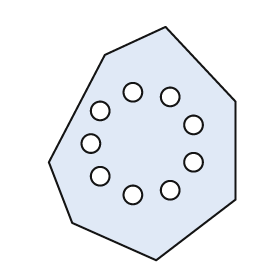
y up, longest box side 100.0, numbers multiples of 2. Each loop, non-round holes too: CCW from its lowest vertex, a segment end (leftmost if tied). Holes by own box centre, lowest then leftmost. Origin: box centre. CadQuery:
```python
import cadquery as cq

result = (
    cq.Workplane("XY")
    .moveTo(6.0, -50.0)
    .lineTo(40.0, -24.0)
    .lineTo(40.0, 18.0)
    .lineTo(10.0, 50.0)
    .lineTo(-16.0, 38.0)
    .lineTo(-40.0, -8.0)
    .lineTo(-30.0, -34.0)
    .close()
    .moveTo(-4.0, -22.0)
    .circle(4.0)
    .moveTo(12.0, -20.0)
    .circle(4.0)
    .moveTo(-18.0, -14.0)
    .circle(4.0)
    .moveTo(22.0, -8.0)
    .circle(4.0)
    .moveTo(-22.0, 0.0)
    .circle(4.0)
    .moveTo(22.0, 8.0)
    .circle(4.0)
    .moveTo(-18.0, 14.0)
    .circle(4.0)
    .moveTo(12.0, 20.0)
    .circle(4.0)
    .moveTo(-4.0, 22.0)
    .circle(4.0)
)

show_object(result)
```